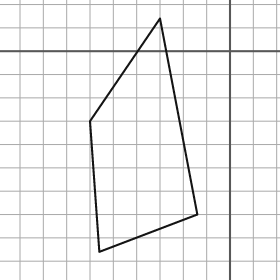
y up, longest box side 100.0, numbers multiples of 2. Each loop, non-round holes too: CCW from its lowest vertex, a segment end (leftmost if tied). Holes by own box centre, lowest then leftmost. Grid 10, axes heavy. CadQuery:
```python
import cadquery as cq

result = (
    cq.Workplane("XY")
    .moveTo(-56.0, -86.0)
    .lineTo(-14.0, -70.0)
    .lineTo(-30.0, 14.0)
    .lineTo(-60.0, -30.0)
    .close()
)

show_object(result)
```